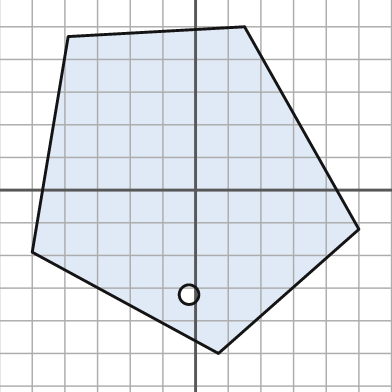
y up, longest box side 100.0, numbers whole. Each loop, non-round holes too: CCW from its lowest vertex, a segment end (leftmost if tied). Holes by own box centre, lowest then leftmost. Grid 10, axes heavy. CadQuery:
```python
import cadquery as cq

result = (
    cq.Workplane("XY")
    .moveTo(7.0, -50.0)
    .lineTo(50.0, -12.0)
    .lineTo(15.0, 50.0)
    .lineTo(-39.0, 47.0)
    .lineTo(-50.0, -19.0)
    .close()
    .moveTo(-2.0, -32.0)
    .circle(3.0)
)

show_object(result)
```